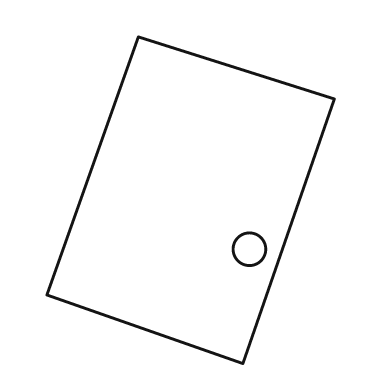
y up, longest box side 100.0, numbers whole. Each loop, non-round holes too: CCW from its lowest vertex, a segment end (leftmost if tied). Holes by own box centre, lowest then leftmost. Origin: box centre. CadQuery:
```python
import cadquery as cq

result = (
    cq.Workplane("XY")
    .moveTo(16.0, -50.0)
    .lineTo(44.0, 31.0)
    .lineTo(-16.0, 50.0)
    .lineTo(-44.0, -29.0)
    .close()
    .moveTo(18.0, -15.0)
    .circle(5.0)
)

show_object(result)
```